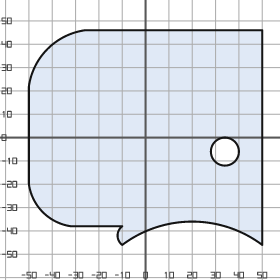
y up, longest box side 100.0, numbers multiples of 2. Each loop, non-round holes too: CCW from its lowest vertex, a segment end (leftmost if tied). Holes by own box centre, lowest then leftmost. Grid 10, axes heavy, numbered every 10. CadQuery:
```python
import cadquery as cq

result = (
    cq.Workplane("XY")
    .moveTo(-10.0, -46.0)
    .threePointArc((20.0, -36.0), (50.0, -46.0))
    .lineTo(50.0, 46.0)
    .lineTo(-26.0, 46.0)
    .threePointArc((-42.0, 38.0), (-50.0, 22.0))
    .lineTo(-50.0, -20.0)
    .threePointArc((-44.0, -32.0), (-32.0, -38.0))
    .lineTo(-10.0, -38.0)
    .threePointArc((-12.0, -42.0), (-10.0, -46.0))
    .close()
    .moveTo(34.0, -6.0)
    .circle(6.0)
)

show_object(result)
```